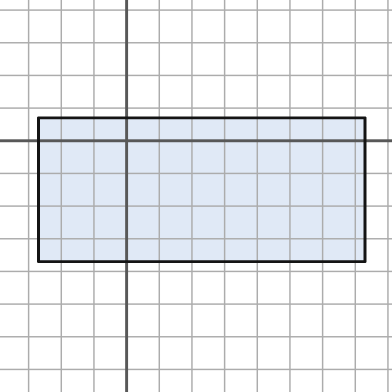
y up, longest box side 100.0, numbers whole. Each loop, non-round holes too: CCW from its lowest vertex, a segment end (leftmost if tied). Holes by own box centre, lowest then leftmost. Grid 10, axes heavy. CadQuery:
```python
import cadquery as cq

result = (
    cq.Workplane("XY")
    .moveTo(-27.0, -37.0)
    .lineTo(73.0, -37.0)
    .lineTo(73.0, 7.0)
    .lineTo(-27.0, 7.0)
    .close()
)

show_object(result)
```